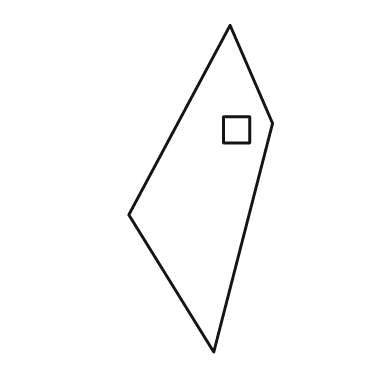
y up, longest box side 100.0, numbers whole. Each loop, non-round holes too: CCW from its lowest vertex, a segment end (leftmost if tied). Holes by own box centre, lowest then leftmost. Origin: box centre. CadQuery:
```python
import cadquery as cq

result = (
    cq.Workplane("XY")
    .moveTo(4.0, -50.0)
    .lineTo(22.0, 20.0)
    .lineTo(9.0, 50.0)
    .lineTo(-22.0, -8.0)
    .close()
    .moveTo(7.0, 14.0)
    .lineTo(15.0, 14.0)
    .lineTo(15.0, 22.0)
    .lineTo(7.0, 22.0)
    .close()
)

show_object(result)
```